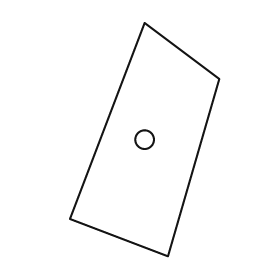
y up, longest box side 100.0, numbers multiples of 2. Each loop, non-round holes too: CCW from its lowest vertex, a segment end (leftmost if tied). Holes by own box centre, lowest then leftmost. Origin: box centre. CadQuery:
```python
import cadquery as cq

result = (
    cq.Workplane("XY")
    .moveTo(10.0, -50.0)
    .lineTo(32.0, 26.0)
    .lineTo(0.0, 50.0)
    .lineTo(-32.0, -34.0)
    .close()
    .moveTo(0.0, 0.0)
    .circle(4.0)
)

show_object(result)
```